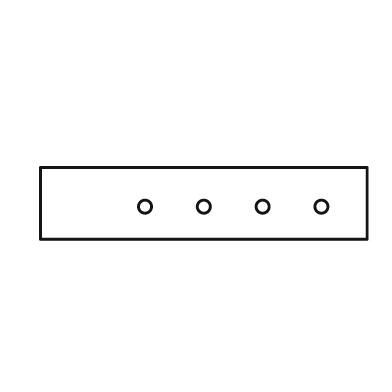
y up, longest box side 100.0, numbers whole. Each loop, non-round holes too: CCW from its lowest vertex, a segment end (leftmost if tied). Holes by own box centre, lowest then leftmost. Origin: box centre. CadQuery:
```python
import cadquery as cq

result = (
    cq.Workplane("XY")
    .moveTo(-50.0, -11.0)
    .lineTo(50.0, -11.0)
    .lineTo(50.0, 11.0)
    .lineTo(-50.0, 11.0)
    .close()
    .moveTo(-18.0, -1.0)
    .circle(2.0)
    .moveTo(0.0, -1.0)
    .circle(2.0)
    .moveTo(18.0, -1.0)
    .circle(2.0)
    .moveTo(36.0, -1.0)
    .circle(2.0)
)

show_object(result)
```